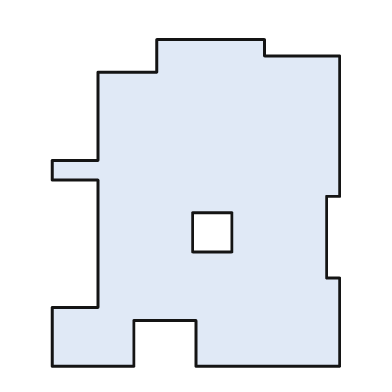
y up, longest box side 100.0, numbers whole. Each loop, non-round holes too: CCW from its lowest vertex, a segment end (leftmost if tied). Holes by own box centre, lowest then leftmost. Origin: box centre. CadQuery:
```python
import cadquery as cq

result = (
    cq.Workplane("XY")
    .moveTo(-44.0, -50.0)
    .lineTo(-19.0, -50.0)
    .lineTo(-19.0, -36.0)
    .lineTo(0.0, -36.0)
    .lineTo(0.0, -50.0)
    .lineTo(44.0, -50.0)
    .lineTo(44.0, -23.0)
    .lineTo(40.0, -23.0)
    .lineTo(40.0, 2.0)
    .lineTo(44.0, 2.0)
    .lineTo(44.0, 45.0)
    .lineTo(21.0, 45.0)
    .lineTo(21.0, 50.0)
    .lineTo(-12.0, 50.0)
    .lineTo(-12.0, 40.0)
    .lineTo(-30.0, 40.0)
    .lineTo(-30.0, 13.0)
    .lineTo(-44.0, 13.0)
    .lineTo(-44.0, 7.0)
    .lineTo(-30.0, 7.0)
    .lineTo(-30.0, -32.0)
    .lineTo(-44.0, -32.0)
    .close()
    .moveTo(-1.0, -15.0)
    .lineTo(11.0, -15.0)
    .lineTo(11.0, -3.0)
    .lineTo(-1.0, -3.0)
    .close()
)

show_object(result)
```